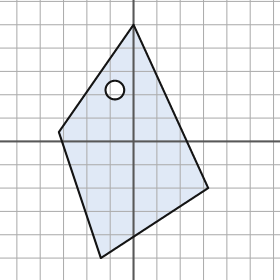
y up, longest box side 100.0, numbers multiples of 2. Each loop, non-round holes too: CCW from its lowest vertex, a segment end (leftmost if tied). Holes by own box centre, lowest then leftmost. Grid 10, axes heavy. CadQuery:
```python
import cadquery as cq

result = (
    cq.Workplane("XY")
    .moveTo(-14.0, -50.0)
    .lineTo(32.0, -20.0)
    .lineTo(0.0, 50.0)
    .lineTo(-32.0, 4.0)
    .close()
    .moveTo(-8.0, 22.0)
    .circle(4.0)
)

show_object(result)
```